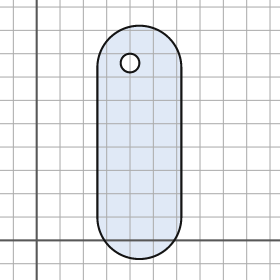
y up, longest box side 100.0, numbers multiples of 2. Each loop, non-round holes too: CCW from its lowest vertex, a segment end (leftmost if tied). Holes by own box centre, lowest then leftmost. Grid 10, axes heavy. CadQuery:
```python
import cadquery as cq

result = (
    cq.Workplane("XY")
    .moveTo(26.0, 10.0)
    .threePointArc((44.0, -8.0), (62.0, 10.0))
    .lineTo(62.0, 74.0)
    .threePointArc((44.0, 92.0), (26.0, 74.0))
    .close()
    .moveTo(40.0, 76.0)
    .circle(4.0)
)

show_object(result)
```